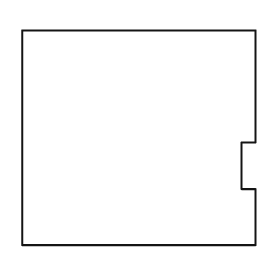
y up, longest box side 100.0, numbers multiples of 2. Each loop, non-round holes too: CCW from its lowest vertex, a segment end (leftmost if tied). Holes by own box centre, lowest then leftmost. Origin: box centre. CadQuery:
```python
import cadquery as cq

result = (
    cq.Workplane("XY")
    .moveTo(-50.0, -46.0)
    .lineTo(50.0, -46.0)
    .lineTo(50.0, -22.0)
    .lineTo(44.0, -22.0)
    .lineTo(44.0, -2.0)
    .lineTo(50.0, -2.0)
    .lineTo(50.0, 46.0)
    .lineTo(-50.0, 46.0)
    .close()
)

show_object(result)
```